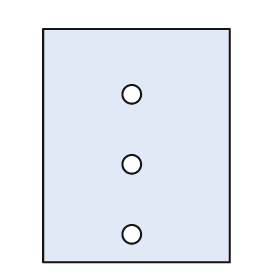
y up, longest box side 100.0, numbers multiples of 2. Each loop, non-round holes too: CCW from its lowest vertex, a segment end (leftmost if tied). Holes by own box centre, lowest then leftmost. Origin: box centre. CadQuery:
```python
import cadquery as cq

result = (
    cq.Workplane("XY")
    .moveTo(-40.0, -50.0)
    .lineTo(40.0, -50.0)
    .lineTo(40.0, 50.0)
    .lineTo(-40.0, 50.0)
    .close()
    .moveTo(-2.0, -38.0)
    .circle(4.0)
    .moveTo(-2.0, -8.0)
    .circle(4.0)
    .moveTo(-2.0, 22.0)
    .circle(4.0)
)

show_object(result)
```